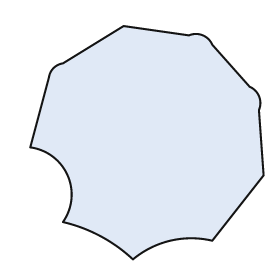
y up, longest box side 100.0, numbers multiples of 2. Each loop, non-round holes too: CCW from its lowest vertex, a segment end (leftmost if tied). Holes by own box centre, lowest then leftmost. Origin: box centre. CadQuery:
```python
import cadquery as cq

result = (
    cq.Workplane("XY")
    .moveTo(-6.0, -50.0)
    .threePointArc((10.0, -42.0), (28.0, -42.0))
    .lineTo(50.0, -14.0)
    .lineTo(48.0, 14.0)
    .threePointArc((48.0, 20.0), (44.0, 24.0))
    .lineTo(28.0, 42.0)
    .threePointArc((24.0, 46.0), (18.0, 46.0))
    .lineTo(-10.0, 50.0)
    .lineTo(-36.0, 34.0)
    .threePointArc((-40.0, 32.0), (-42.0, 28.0))
    .lineTo(-50.0, -2.0)
    .threePointArc((-34.0, -14.0), (-36.0, -34.0))
    .threePointArc((-20.0, -40.0), (-6.0, -50.0))
    .close()
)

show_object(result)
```